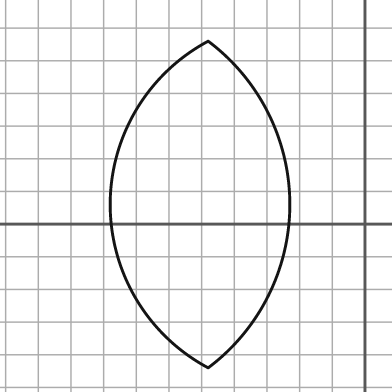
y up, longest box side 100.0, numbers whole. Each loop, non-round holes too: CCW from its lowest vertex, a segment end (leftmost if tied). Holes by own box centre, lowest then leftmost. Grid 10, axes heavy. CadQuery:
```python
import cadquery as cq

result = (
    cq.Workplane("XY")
    .moveTo(-48.0, -44.0)
    .threePointArc((-23.0, 6.0), (-48.0, 56.0))
    .threePointArc((-78.0, 6.0), (-48.0, -44.0))
    .close()
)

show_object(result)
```